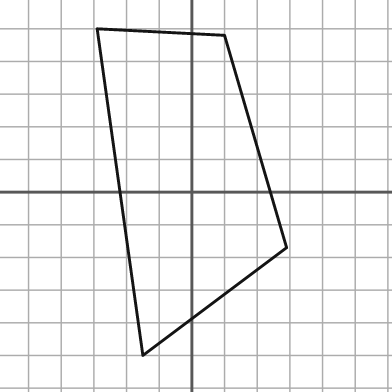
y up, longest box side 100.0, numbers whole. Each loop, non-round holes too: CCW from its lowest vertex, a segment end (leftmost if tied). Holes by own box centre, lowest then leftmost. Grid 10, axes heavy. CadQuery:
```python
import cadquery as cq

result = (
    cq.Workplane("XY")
    .moveTo(-15.0, -50.0)
    .lineTo(29.0, -17.0)
    .lineTo(10.0, 48.0)
    .lineTo(-29.0, 50.0)
    .close()
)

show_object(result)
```